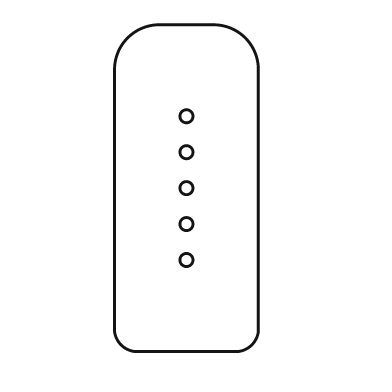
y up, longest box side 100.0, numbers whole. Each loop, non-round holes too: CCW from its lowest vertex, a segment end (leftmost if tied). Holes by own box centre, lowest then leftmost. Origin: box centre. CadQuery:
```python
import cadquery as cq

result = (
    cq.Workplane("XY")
    .moveTo(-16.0, -50.0)
    .lineTo(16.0, -50.0)
    .threePointArc((20.0, -48.0), (22.0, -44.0))
    .lineTo(22.0, 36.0)
    .threePointArc((18.0, 46.0), (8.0, 50.0))
    .lineTo(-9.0, 50.0)
    .threePointArc((-18.0, 46.0), (-22.0, 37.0))
    .lineTo(-22.0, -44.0)
    .threePointArc((-20.0, -48.0), (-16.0, -50.0))
    .close()
    .moveTo(0.0, -22.0)
    .circle(2.0)
    .moveTo(0.0, -11.0)
    .circle(2.0)
    .moveTo(0.0, 0.0)
    .circle(2.0)
    .moveTo(0.0, 11.0)
    .circle(2.0)
    .moveTo(0.0, 22.0)
    .circle(2.0)
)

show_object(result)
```